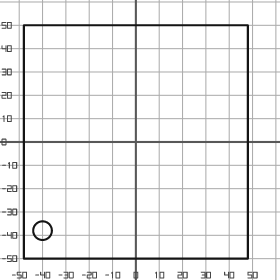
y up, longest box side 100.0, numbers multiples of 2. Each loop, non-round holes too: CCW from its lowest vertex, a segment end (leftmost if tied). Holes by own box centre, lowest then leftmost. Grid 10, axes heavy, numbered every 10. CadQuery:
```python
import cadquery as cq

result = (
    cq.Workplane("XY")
    .moveTo(-48.0, -50.0)
    .lineTo(48.0, -50.0)
    .lineTo(48.0, 50.0)
    .lineTo(-48.0, 50.0)
    .close()
    .moveTo(-40.0, -38.0)
    .circle(4.0)
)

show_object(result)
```